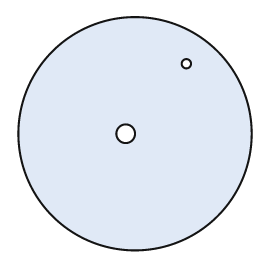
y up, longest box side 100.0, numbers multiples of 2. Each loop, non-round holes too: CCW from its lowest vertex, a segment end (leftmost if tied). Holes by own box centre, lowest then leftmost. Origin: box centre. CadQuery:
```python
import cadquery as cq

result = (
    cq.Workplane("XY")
    .moveTo(0.0, 0.0)
    .circle(50.0)
    .moveTo(-4.0, 0.0)
    .circle(4.0)
    .moveTo(22.0, 30.0)
    .circle(2.0)
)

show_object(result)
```